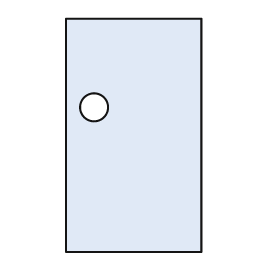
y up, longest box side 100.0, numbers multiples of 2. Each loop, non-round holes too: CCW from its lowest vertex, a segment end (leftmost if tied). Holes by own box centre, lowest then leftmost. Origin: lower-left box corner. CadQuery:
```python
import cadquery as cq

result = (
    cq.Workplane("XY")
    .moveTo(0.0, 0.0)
    .lineTo(58.0, 0.0)
    .lineTo(58.0, 100.0)
    .lineTo(0.0, 100.0)
    .close()
    .moveTo(12.0, 62.0)
    .circle(6.0)
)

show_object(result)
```